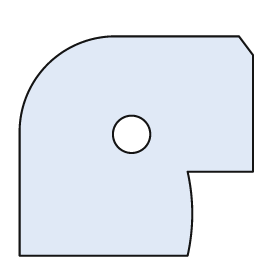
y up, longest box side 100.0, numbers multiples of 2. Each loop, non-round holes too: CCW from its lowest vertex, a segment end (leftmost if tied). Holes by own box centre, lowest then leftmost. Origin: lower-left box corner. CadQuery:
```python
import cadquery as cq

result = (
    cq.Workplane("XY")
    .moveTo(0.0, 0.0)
    .lineTo(72.0, 0.0)
    .threePointArc((74.0, 18.0), (72.0, 36.0))
    .lineTo(100.0, 36.0)
    .lineTo(100.0, 86.0)
    .lineTo(94.0, 94.0)
    .lineTo(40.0, 94.0)
    .threePointArc((12.0, 82.0), (0.0, 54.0))
    .close()
    .moveTo(48.0, 52.0)
    .circle(8.0)
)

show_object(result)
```